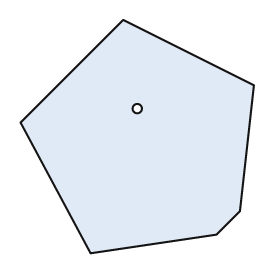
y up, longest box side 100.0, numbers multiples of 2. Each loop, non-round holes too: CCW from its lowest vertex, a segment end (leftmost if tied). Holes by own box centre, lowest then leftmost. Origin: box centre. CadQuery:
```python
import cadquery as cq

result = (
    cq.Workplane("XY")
    .moveTo(-20.0, -50.0)
    .lineTo(34.0, -42.0)
    .lineTo(44.0, -32.0)
    .lineTo(50.0, 22.0)
    .lineTo(-6.0, 50.0)
    .lineTo(-50.0, 6.0)
    .close()
    .moveTo(0.0, 12.0)
    .circle(2.0)
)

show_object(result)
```